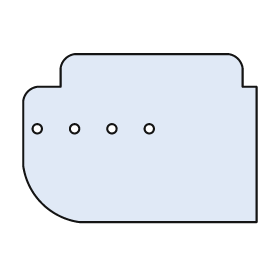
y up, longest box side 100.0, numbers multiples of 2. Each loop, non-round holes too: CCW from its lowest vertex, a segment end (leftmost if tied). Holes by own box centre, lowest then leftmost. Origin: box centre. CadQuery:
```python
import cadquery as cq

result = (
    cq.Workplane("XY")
    .moveTo(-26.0, -36.0)
    .lineTo(50.0, -36.0)
    .lineTo(50.0, 22.0)
    .lineTo(44.0, 22.0)
    .lineTo(44.0, 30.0)
    .threePointArc((42.0, 34.0), (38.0, 36.0))
    .lineTo(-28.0, 36.0)
    .threePointArc((-32.0, 34.0), (-34.0, 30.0))
    .lineTo(-34.0, 22.0)
    .lineTo(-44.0, 22.0)
    .threePointArc((-48.0, 20.0), (-50.0, 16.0))
    .lineTo(-50.0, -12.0)
    .threePointArc((-42.0, -28.0), (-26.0, -36.0))
    .close()
    .moveTo(-44.0, 4.0)
    .circle(2.0)
    .moveTo(-28.0, 4.0)
    .circle(2.0)
    .moveTo(-12.0, 4.0)
    .circle(2.0)
    .moveTo(4.0, 4.0)
    .circle(2.0)
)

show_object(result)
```